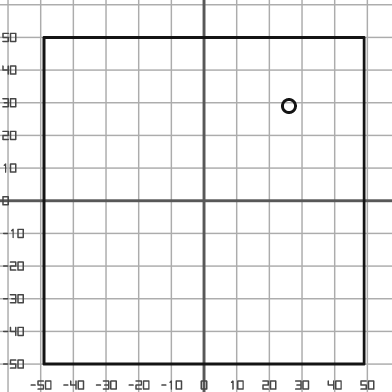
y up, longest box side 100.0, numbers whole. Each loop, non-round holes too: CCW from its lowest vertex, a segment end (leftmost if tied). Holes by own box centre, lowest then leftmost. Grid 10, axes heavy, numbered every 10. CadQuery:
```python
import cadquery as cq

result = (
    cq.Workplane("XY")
    .moveTo(-49.0, -50.0)
    .lineTo(49.0, -50.0)
    .lineTo(49.0, 50.0)
    .lineTo(-49.0, 50.0)
    .close()
    .moveTo(26.0, 29.0)
    .circle(2.0)
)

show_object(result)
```